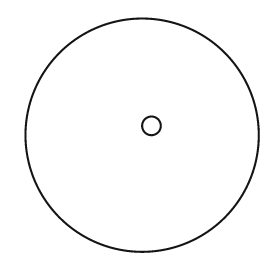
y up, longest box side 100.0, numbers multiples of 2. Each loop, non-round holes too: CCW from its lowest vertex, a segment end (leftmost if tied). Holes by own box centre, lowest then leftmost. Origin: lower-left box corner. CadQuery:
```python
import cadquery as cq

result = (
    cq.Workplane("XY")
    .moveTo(50.0, 50.0)
    .circle(50.0)
    .moveTo(54.0, 54.0)
    .circle(4.0)
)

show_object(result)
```